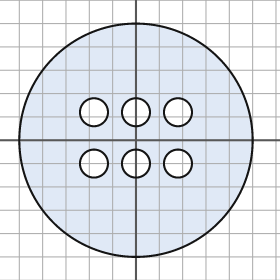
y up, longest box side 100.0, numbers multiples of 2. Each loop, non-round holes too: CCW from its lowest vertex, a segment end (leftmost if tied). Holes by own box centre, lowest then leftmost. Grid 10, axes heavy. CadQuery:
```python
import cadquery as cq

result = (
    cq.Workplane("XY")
    .moveTo(0.0, 0.0)
    .circle(50.0)
    .moveTo(-18.0, -10.0)
    .circle(6.0)
    .moveTo(0.0, -10.0)
    .circle(6.0)
    .moveTo(18.0, -10.0)
    .circle(6.0)
    .moveTo(-18.0, 12.0)
    .circle(6.0)
    .moveTo(0.0, 12.0)
    .circle(6.0)
    .moveTo(18.0, 12.0)
    .circle(6.0)
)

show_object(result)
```